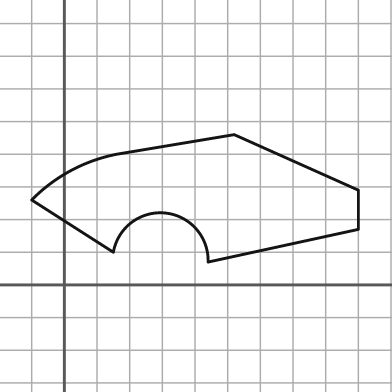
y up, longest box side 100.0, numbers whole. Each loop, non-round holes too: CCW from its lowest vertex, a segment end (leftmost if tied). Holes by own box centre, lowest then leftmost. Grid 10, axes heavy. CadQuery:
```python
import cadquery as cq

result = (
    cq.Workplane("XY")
    .moveTo(44.0, 7.0)
    .lineTo(90.0, 17.0)
    .lineTo(90.0, 29.0)
    .lineTo(52.0, 46.0)
    .lineTo(16.0, 40.0)
    .threePointArc((2.0, 35.0), (-10.0, 26.0))
    .lineTo(15.0, 10.0)
    .threePointArc((31.0, 22.0), (44.0, 7.0))
    .close()
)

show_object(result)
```